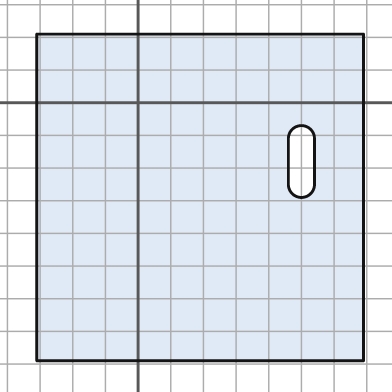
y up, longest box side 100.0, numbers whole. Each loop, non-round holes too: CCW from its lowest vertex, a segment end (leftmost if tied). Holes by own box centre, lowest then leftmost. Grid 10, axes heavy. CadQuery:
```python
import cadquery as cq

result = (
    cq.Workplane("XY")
    .moveTo(-31.0, -79.0)
    .lineTo(69.0, -79.0)
    .lineTo(69.0, 21.0)
    .lineTo(-31.0, 21.0)
    .close()
    .moveTo(46.0, -25.0)
    .threePointArc((50.0, -29.0), (54.0, -25.0))
    .lineTo(54.0, -11.0)
    .threePointArc((50.0, -7.0), (46.0, -11.0))
    .close()
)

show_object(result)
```